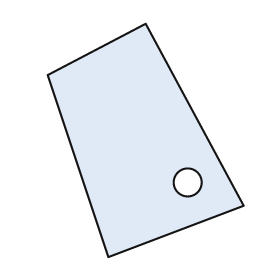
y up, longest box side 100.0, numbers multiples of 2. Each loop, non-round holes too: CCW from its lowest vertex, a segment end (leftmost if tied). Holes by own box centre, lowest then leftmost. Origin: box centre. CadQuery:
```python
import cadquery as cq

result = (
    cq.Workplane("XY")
    .moveTo(-16.0, -50.0)
    .lineTo(42.0, -28.0)
    .lineTo(0.0, 50.0)
    .lineTo(-42.0, 28.0)
    .close()
    .moveTo(18.0, -18.0)
    .circle(6.0)
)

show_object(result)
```